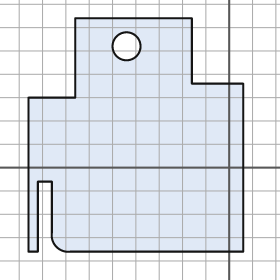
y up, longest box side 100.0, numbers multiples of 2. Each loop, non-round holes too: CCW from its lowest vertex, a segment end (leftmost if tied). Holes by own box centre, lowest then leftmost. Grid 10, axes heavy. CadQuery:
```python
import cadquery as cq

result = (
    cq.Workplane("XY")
    .moveTo(-86.0, -36.0)
    .lineTo(-82.0, -36.0)
    .lineTo(-82.0, -6.0)
    .lineTo(-76.0, -6.0)
    .lineTo(-76.0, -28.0)
    .threePointArc((-74.0, -34.0), (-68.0, -36.0))
    .lineTo(6.0, -36.0)
    .lineTo(6.0, 36.0)
    .lineTo(-16.0, 36.0)
    .lineTo(-16.0, 64.0)
    .lineTo(-66.0, 64.0)
    .lineTo(-66.0, 30.0)
    .lineTo(-86.0, 30.0)
    .close()
    .moveTo(-44.0, 52.0)
    .circle(6.0)
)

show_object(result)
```